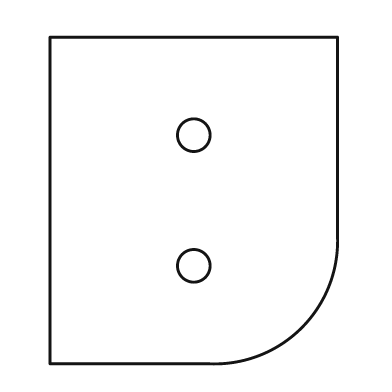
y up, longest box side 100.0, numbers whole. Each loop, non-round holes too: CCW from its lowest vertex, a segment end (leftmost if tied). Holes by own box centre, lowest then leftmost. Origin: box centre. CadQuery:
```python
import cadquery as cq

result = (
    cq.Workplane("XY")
    .moveTo(-44.0, -50.0)
    .lineTo(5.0, -50.0)
    .threePointArc((33.0, -39.0), (44.0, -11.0))
    .lineTo(44.0, 50.0)
    .lineTo(-44.0, 50.0)
    .close()
    .moveTo(0.0, -20.0)
    .circle(5.0)
    .moveTo(0.0, 20.0)
    .circle(5.0)
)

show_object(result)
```